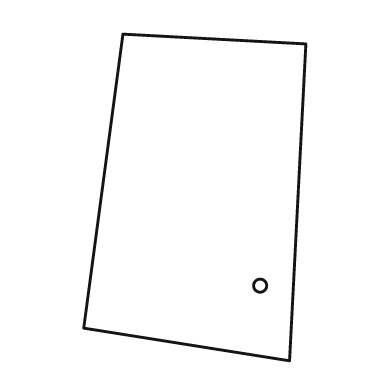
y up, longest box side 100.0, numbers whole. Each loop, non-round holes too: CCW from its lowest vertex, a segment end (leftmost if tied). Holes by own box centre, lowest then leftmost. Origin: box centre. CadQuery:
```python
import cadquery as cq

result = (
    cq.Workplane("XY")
    .moveTo(29.0, -50.0)
    .lineTo(34.0, 47.0)
    .lineTo(-22.0, 50.0)
    .lineTo(-34.0, -40.0)
    .close()
    .moveTo(20.0, -27.0)
    .circle(2.0)
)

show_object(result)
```